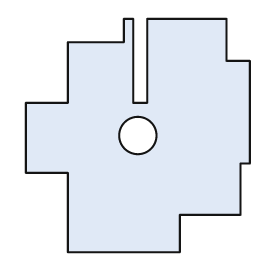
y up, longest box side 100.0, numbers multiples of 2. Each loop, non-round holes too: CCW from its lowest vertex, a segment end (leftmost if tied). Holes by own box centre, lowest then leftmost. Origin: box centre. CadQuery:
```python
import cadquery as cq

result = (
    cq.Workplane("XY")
    .moveTo(-30.0, -50.0)
    .lineTo(18.0, -50.0)
    .lineTo(18.0, -34.0)
    .lineTo(44.0, -34.0)
    .lineTo(44.0, -12.0)
    .lineTo(48.0, -12.0)
    .lineTo(48.0, 32.0)
    .lineTo(38.0, 32.0)
    .lineTo(38.0, 50.0)
    .lineTo(4.0, 50.0)
    .lineTo(4.0, 14.0)
    .lineTo(-2.0, 14.0)
    .lineTo(-2.0, 50.0)
    .lineTo(-6.0, 50.0)
    .lineTo(-6.0, 40.0)
    .lineTo(-30.0, 40.0)
    .lineTo(-30.0, 14.0)
    .lineTo(-48.0, 14.0)
    .lineTo(-48.0, -16.0)
    .lineTo(-30.0, -16.0)
    .close()
    .moveTo(0.0, 0.0)
    .circle(8.0)
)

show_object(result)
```